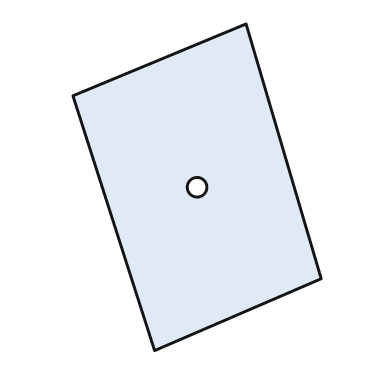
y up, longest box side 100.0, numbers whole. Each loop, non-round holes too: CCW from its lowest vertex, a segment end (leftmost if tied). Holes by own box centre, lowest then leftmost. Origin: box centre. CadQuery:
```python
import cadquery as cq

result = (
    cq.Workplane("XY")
    .moveTo(-13.0, -50.0)
    .lineTo(38.0, -28.0)
    .lineTo(15.0, 50.0)
    .lineTo(-38.0, 28.0)
    .close()
    .moveTo(0.0, 0.0)
    .circle(3.0)
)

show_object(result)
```